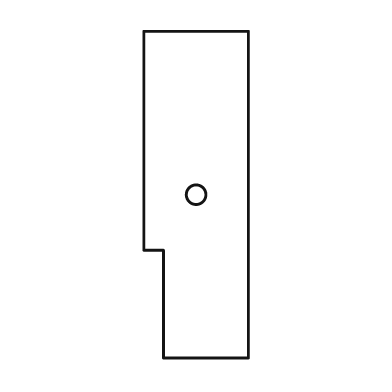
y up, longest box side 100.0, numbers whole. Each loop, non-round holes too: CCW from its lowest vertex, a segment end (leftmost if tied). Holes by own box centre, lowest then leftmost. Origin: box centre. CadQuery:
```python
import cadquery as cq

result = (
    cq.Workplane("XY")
    .moveTo(-10.0, -50.0)
    .lineTo(16.0, -50.0)
    .lineTo(16.0, 50.0)
    .lineTo(-16.0, 50.0)
    .lineTo(-16.0, -17.0)
    .lineTo(-10.0, -17.0)
    .close()
    .moveTo(0.0, 0.0)
    .circle(3.0)
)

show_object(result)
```